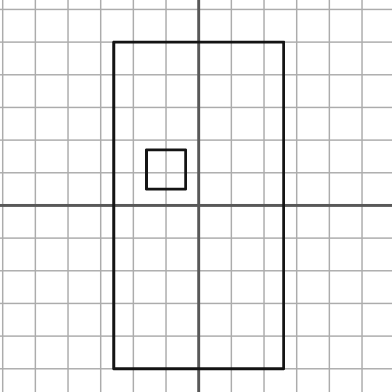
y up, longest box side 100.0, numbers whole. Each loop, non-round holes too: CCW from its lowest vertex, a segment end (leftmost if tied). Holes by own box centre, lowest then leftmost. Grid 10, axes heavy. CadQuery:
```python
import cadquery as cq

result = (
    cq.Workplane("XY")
    .moveTo(-26.0, -50.0)
    .lineTo(26.0, -50.0)
    .lineTo(26.0, 50.0)
    .lineTo(-26.0, 50.0)
    .close()
    .moveTo(-16.0, 5.0)
    .lineTo(-4.0, 5.0)
    .lineTo(-4.0, 17.0)
    .lineTo(-16.0, 17.0)
    .close()
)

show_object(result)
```